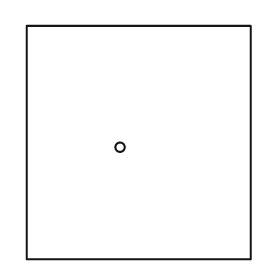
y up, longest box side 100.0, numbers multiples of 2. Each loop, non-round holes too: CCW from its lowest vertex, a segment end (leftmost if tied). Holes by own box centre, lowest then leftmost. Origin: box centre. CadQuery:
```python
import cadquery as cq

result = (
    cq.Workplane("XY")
    .moveTo(-48.0, -50.0)
    .lineTo(48.0, -50.0)
    .lineTo(48.0, 50.0)
    .lineTo(-48.0, 50.0)
    .close()
    .moveTo(-8.0, -2.0)
    .circle(2.0)
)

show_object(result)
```